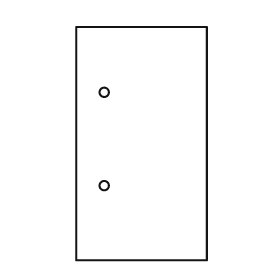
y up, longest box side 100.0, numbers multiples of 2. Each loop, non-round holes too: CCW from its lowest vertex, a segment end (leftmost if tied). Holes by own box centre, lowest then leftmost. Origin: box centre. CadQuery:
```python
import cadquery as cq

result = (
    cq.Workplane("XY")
    .moveTo(-28.0, -50.0)
    .lineTo(28.0, -50.0)
    .lineTo(28.0, 50.0)
    .lineTo(-28.0, 50.0)
    .close()
    .moveTo(-16.0, -18.0)
    .circle(2.0)
    .moveTo(-16.0, 22.0)
    .circle(2.0)
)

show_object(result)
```